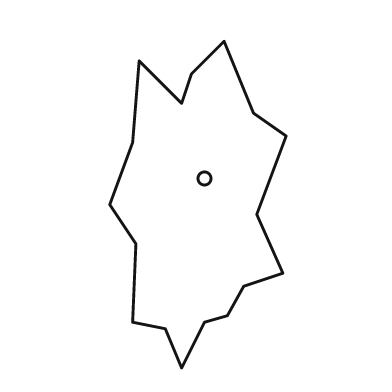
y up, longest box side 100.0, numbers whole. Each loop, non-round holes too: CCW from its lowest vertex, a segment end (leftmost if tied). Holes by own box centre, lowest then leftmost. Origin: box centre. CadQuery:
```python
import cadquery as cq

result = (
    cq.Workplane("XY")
    .moveTo(-5.0, -50.0)
    .lineTo(2.0, -36.0)
    .lineTo(9.0, -34.0)
    .lineTo(14.0, -25.0)
    .lineTo(26.0, -21.0)
    .lineTo(18.0, -3.0)
    .lineTo(27.0, 21.0)
    .lineTo(17.0, 28.0)
    .lineTo(8.0, 50.0)
    .lineTo(-2.0, 40.0)
    .lineTo(-5.0, 31.0)
    .lineTo(-18.0, 44.0)
    .lineTo(-20.0, 19.0)
    .lineTo(-27.0, 0.0)
    .lineTo(-19.0, -12.0)
    .lineTo(-20.0, -36.0)
    .lineTo(-10.0, -38.0)
    .close()
    .moveTo(2.0, 8.0)
    .circle(2.0)
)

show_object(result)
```